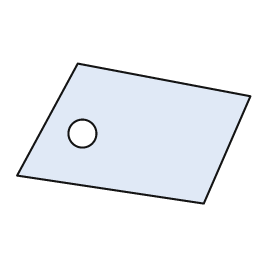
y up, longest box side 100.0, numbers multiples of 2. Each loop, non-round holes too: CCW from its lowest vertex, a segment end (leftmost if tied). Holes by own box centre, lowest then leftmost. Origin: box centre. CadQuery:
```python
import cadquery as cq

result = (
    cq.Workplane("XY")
    .moveTo(30.0, -30.0)
    .lineTo(50.0, 16.0)
    .lineTo(-24.0, 30.0)
    .lineTo(-50.0, -18.0)
    .close()
    .moveTo(-22.0, 0.0)
    .circle(6.0)
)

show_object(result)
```